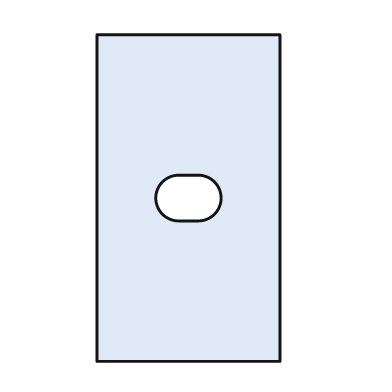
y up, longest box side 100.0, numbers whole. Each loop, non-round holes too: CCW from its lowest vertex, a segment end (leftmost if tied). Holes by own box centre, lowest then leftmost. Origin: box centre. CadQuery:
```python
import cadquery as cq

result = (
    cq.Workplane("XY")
    .moveTo(-28.0, -50.0)
    .lineTo(28.0, -50.0)
    .lineTo(28.0, 50.0)
    .lineTo(-28.0, 50.0)
    .close()
    .moveTo(-3.0, -7.0)
    .lineTo(3.0, -7.0)
    .threePointArc((10.0, 0.0), (3.0, 7.0))
    .lineTo(-3.0, 7.0)
    .threePointArc((-10.0, 0.0), (-3.0, -7.0))
    .close()
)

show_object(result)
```